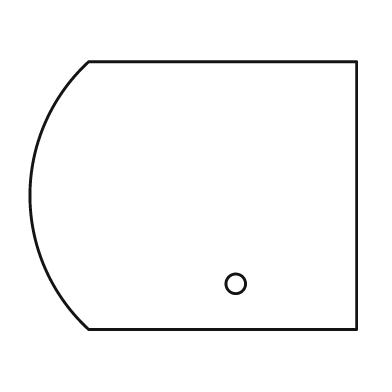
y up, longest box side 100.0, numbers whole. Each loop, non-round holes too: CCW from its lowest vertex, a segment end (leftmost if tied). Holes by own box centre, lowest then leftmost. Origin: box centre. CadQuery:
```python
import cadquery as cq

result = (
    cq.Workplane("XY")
    .moveTo(-32.0, -41.0)
    .lineTo(50.0, -41.0)
    .lineTo(50.0, 41.0)
    .lineTo(-32.0, 41.0)
    .threePointArc((-50.0, 0.0), (-32.0, -41.0))
    .close()
    .moveTo(13.0, -27.0)
    .circle(3.0)
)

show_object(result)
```